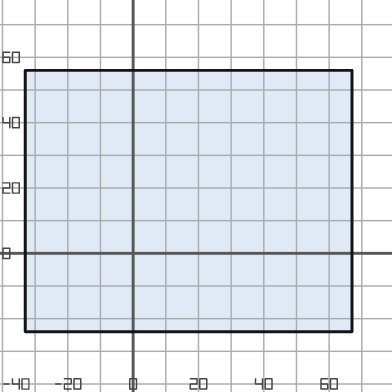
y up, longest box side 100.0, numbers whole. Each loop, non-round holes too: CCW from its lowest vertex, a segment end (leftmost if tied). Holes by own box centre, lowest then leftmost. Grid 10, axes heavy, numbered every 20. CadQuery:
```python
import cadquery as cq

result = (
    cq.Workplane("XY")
    .moveTo(-33.0, -24.0)
    .lineTo(67.0, -24.0)
    .lineTo(67.0, 56.0)
    .lineTo(-33.0, 56.0)
    .close()
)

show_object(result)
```